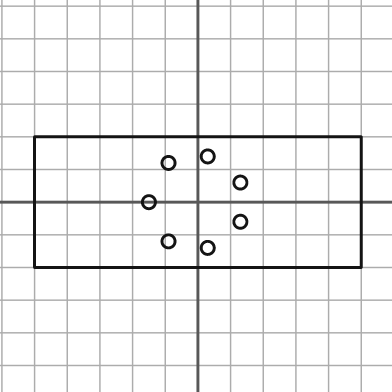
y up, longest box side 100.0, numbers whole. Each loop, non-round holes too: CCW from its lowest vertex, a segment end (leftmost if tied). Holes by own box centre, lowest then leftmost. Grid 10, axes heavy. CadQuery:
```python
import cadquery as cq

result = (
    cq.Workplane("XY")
    .moveTo(-50.0, -20.0)
    .lineTo(50.0, -20.0)
    .lineTo(50.0, 20.0)
    .lineTo(-50.0, 20.0)
    .close()
    .moveTo(3.0, -14.0)
    .circle(2.0)
    .moveTo(-9.0, -12.0)
    .circle(2.0)
    .moveTo(13.0, -6.0)
    .circle(2.0)
    .moveTo(-15.0, 0.0)
    .circle(2.0)
    .moveTo(13.0, 6.0)
    .circle(2.0)
    .moveTo(-9.0, 12.0)
    .circle(2.0)
    .moveTo(3.0, 14.0)
    .circle(2.0)
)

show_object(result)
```